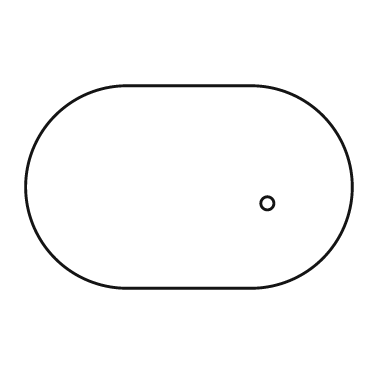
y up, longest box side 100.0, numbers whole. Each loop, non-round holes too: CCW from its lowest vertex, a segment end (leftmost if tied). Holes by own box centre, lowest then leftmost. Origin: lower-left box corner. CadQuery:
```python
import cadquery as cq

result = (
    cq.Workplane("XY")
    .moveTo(31.0, 0.0)
    .lineTo(69.0, 0.0)
    .threePointArc((100.0, 31.0), (69.0, 62.0))
    .lineTo(31.0, 62.0)
    .threePointArc((0.0, 31.0), (31.0, 0.0))
    .close()
    .moveTo(74.0, 26.0)
    .circle(2.0)
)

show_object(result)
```